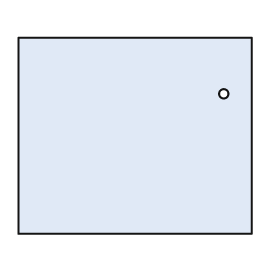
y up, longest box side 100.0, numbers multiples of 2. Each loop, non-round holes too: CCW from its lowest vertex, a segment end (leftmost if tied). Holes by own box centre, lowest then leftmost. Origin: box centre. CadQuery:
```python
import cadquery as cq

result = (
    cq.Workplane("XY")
    .moveTo(-50.0, -42.0)
    .lineTo(50.0, -42.0)
    .lineTo(50.0, 42.0)
    .lineTo(-50.0, 42.0)
    .close()
    .moveTo(38.0, 18.0)
    .circle(2.0)
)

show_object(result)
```